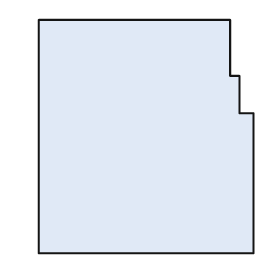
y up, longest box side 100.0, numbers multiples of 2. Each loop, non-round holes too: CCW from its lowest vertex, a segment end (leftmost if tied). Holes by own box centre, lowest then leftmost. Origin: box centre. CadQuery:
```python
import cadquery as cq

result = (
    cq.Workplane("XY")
    .moveTo(-46.0, -50.0)
    .lineTo(46.0, -50.0)
    .lineTo(46.0, 10.0)
    .lineTo(40.0, 10.0)
    .lineTo(40.0, 26.0)
    .lineTo(36.0, 26.0)
    .lineTo(36.0, 50.0)
    .lineTo(-46.0, 50.0)
    .close()
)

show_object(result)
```